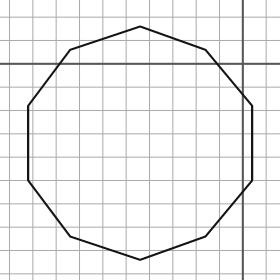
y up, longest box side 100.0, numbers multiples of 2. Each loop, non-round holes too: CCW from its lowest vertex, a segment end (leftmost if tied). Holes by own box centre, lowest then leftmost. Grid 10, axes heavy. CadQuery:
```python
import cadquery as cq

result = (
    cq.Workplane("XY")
    .moveTo(-44.0, -84.0)
    .lineTo(-16.0, -74.0)
    .lineTo(4.0, -50.0)
    .lineTo(4.0, -18.0)
    .lineTo(-16.0, 6.0)
    .lineTo(-44.0, 16.0)
    .lineTo(-74.0, 6.0)
    .lineTo(-92.0, -18.0)
    .lineTo(-92.0, -50.0)
    .lineTo(-74.0, -74.0)
    .close()
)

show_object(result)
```